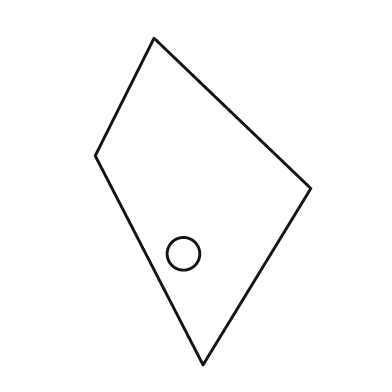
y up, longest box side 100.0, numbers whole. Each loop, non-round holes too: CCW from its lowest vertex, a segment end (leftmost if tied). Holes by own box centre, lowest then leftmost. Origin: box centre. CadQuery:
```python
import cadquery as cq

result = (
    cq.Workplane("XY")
    .moveTo(0.0, -50.0)
    .lineTo(33.0, 4.0)
    .lineTo(-15.0, 50.0)
    .lineTo(-33.0, 14.0)
    .close()
    .moveTo(-6.0, -16.0)
    .circle(5.0)
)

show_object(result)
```